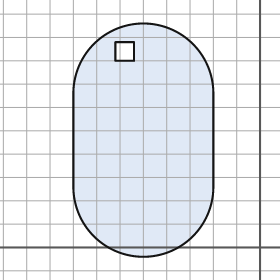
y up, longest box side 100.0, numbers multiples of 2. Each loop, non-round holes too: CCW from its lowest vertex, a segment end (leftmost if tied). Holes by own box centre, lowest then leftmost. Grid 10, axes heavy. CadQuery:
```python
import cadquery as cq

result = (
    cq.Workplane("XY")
    .moveTo(-80.0, 26.0)
    .threePointArc((-50.0, -4.0), (-20.0, 26.0))
    .lineTo(-20.0, 66.0)
    .threePointArc((-50.0, 96.0), (-80.0, 66.0))
    .close()
    .moveTo(-62.0, 80.0)
    .lineTo(-54.0, 80.0)
    .lineTo(-54.0, 88.0)
    .lineTo(-62.0, 88.0)
    .close()
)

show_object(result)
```